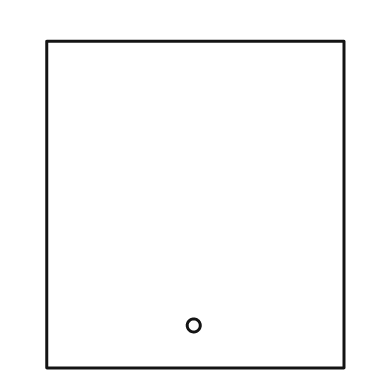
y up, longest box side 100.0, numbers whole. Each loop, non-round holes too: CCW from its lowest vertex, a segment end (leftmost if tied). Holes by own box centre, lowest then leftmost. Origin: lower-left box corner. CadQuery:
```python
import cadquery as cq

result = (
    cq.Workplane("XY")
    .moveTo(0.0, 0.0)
    .lineTo(91.0, 0.0)
    .lineTo(91.0, 100.0)
    .lineTo(0.0, 100.0)
    .close()
    .moveTo(45.0, 13.0)
    .circle(2.0)
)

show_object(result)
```